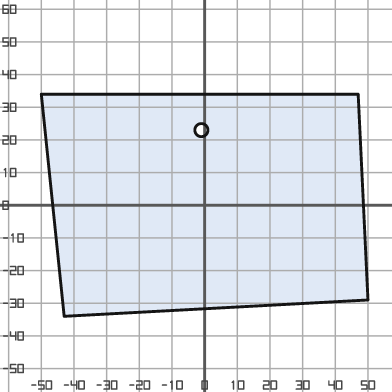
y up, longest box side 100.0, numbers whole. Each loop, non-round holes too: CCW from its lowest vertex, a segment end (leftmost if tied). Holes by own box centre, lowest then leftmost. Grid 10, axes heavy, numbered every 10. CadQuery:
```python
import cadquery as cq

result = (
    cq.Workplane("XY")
    .moveTo(-43.0, -34.0)
    .lineTo(50.0, -29.0)
    .lineTo(47.0, 34.0)
    .lineTo(-50.0, 34.0)
    .close()
    .moveTo(-1.0, 23.0)
    .circle(2.0)
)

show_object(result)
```